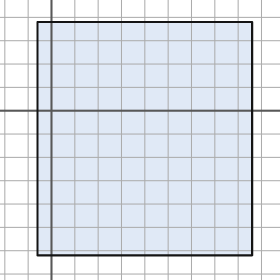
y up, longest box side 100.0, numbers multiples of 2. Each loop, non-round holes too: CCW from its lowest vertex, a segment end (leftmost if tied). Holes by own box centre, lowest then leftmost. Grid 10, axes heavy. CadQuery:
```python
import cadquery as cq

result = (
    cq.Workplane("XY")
    .moveTo(-6.0, -62.0)
    .lineTo(86.0, -62.0)
    .lineTo(86.0, 38.0)
    .lineTo(-6.0, 38.0)
    .close()
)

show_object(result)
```